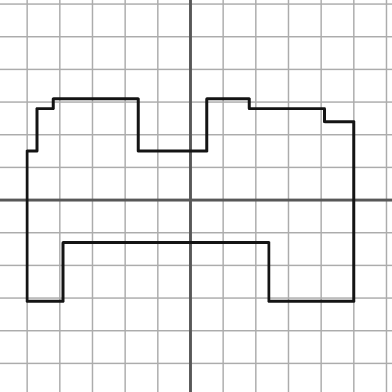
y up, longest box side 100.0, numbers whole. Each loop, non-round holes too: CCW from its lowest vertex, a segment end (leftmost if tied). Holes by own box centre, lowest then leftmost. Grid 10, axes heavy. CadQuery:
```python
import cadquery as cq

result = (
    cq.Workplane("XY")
    .moveTo(-50.0, -31.0)
    .lineTo(-39.0, -31.0)
    .lineTo(-39.0, -13.0)
    .lineTo(24.0, -13.0)
    .lineTo(24.0, -31.0)
    .lineTo(50.0, -31.0)
    .lineTo(50.0, 24.0)
    .lineTo(41.0, 24.0)
    .lineTo(41.0, 28.0)
    .lineTo(18.0, 28.0)
    .lineTo(18.0, 31.0)
    .lineTo(5.0, 31.0)
    .lineTo(5.0, 15.0)
    .lineTo(-16.0, 15.0)
    .lineTo(-16.0, 31.0)
    .lineTo(-42.0, 31.0)
    .lineTo(-42.0, 28.0)
    .lineTo(-47.0, 28.0)
    .lineTo(-47.0, 15.0)
    .lineTo(-50.0, 15.0)
    .close()
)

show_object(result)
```